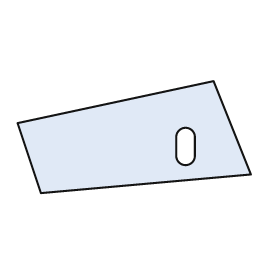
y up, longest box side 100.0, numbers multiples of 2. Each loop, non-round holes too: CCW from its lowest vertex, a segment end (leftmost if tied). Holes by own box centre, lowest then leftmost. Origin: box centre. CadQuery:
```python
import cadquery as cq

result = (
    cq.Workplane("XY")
    .moveTo(-40.0, -24.0)
    .lineTo(50.0, -16.0)
    .lineTo(34.0, 24.0)
    .lineTo(-50.0, 6.0)
    .close()
    .moveTo(18.0, -8.0)
    .threePointArc((22.0, -12.0), (26.0, -8.0))
    .lineTo(26.0, 0.0)
    .threePointArc((22.0, 4.0), (18.0, 0.0))
    .close()
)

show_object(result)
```